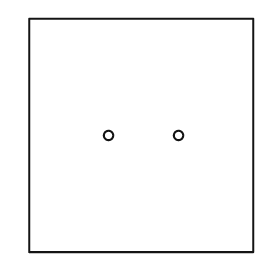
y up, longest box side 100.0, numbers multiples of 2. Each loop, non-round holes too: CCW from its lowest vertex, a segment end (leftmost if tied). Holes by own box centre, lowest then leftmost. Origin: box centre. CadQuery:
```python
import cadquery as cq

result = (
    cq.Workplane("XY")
    .moveTo(-48.0, -50.0)
    .lineTo(48.0, -50.0)
    .lineTo(48.0, 50.0)
    .lineTo(-48.0, 50.0)
    .close()
    .moveTo(-14.0, 0.0)
    .circle(2.0)
    .moveTo(16.0, 0.0)
    .circle(2.0)
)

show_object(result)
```